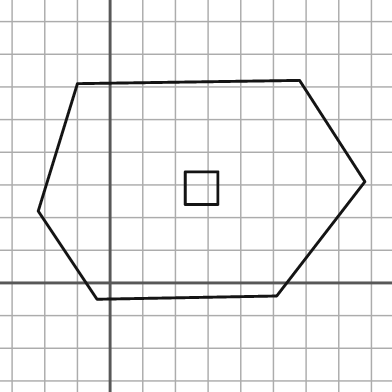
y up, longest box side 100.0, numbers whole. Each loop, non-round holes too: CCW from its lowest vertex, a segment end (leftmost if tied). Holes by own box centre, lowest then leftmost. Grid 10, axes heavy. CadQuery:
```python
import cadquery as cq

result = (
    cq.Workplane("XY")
    .moveTo(-4.0, -5.0)
    .lineTo(51.0, -4.0)
    .lineTo(78.0, 31.0)
    .lineTo(58.0, 62.0)
    .lineTo(-10.0, 61.0)
    .lineTo(-22.0, 22.0)
    .close()
    .moveTo(23.0, 24.0)
    .lineTo(33.0, 24.0)
    .lineTo(33.0, 34.0)
    .lineTo(23.0, 34.0)
    .close()
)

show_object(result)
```